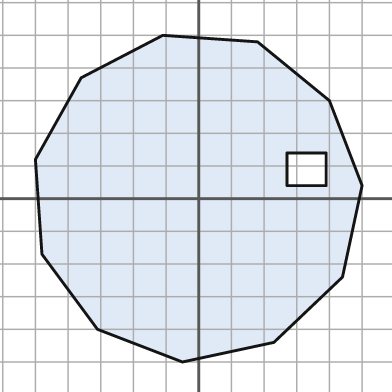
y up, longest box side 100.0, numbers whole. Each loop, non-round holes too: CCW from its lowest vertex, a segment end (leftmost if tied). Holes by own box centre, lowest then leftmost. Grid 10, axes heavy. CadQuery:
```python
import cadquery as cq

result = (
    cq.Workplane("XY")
    .moveTo(-5.0, -50.0)
    .lineTo(23.0, -44.0)
    .lineTo(44.0, -24.0)
    .lineTo(50.0, 4.0)
    .lineTo(40.0, 30.0)
    .lineTo(18.0, 48.0)
    .lineTo(-11.0, 50.0)
    .lineTo(-36.0, 37.0)
    .lineTo(-50.0, 12.0)
    .lineTo(-48.0, -17.0)
    .lineTo(-31.0, -40.0)
    .close()
    .moveTo(27.0, 4.0)
    .lineTo(39.0, 4.0)
    .lineTo(39.0, 14.0)
    .lineTo(27.0, 14.0)
    .close()
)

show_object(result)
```